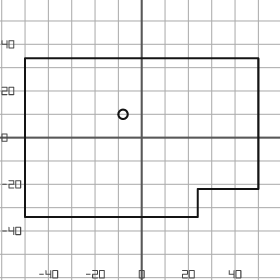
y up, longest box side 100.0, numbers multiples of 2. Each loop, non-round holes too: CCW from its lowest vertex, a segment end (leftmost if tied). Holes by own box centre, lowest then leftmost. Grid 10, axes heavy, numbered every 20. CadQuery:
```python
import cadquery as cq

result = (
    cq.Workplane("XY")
    .moveTo(-50.0, -34.0)
    .lineTo(24.0, -34.0)
    .lineTo(24.0, -22.0)
    .lineTo(50.0, -22.0)
    .lineTo(50.0, 34.0)
    .lineTo(-50.0, 34.0)
    .close()
    .moveTo(-8.0, 10.0)
    .circle(2.0)
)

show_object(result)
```